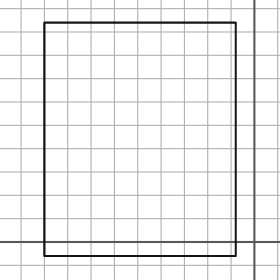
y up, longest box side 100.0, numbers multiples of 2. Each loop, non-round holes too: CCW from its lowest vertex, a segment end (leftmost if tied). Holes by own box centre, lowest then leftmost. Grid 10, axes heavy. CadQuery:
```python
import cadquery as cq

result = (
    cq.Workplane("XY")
    .moveTo(-90.0, -6.0)
    .lineTo(-8.0, -6.0)
    .lineTo(-8.0, 94.0)
    .lineTo(-90.0, 94.0)
    .close()
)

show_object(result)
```